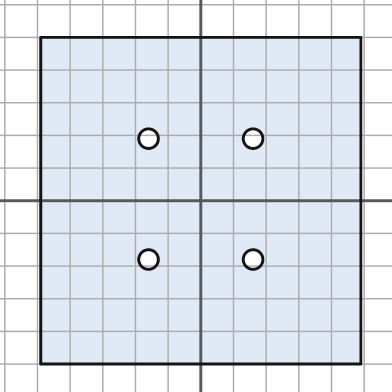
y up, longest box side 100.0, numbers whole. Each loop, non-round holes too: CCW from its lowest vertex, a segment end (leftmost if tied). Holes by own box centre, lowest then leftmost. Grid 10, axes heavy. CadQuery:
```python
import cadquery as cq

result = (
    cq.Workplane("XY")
    .moveTo(-49.0, -50.0)
    .lineTo(49.0, -50.0)
    .lineTo(49.0, 50.0)
    .lineTo(-49.0, 50.0)
    .close()
    .moveTo(-16.0, -18.0)
    .circle(3.0)
    .moveTo(16.0, -18.0)
    .circle(3.0)
    .moveTo(-16.0, 19.0)
    .circle(3.0)
    .moveTo(16.0, 19.0)
    .circle(3.0)
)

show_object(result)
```